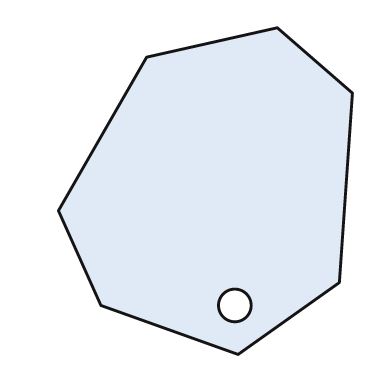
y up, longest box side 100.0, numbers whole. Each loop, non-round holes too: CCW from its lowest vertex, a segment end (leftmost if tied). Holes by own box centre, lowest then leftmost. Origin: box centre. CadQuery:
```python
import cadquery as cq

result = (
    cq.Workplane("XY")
    .moveTo(10.0, -50.0)
    .lineTo(41.0, -28.0)
    .lineTo(45.0, 30.0)
    .lineTo(22.0, 50.0)
    .lineTo(-18.0, 41.0)
    .lineTo(-45.0, -6.0)
    .lineTo(-32.0, -35.0)
    .close()
    .moveTo(9.0, -35.0)
    .circle(5.0)
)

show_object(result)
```